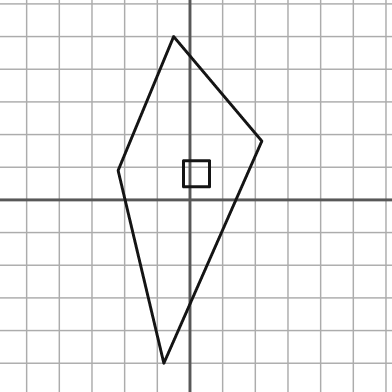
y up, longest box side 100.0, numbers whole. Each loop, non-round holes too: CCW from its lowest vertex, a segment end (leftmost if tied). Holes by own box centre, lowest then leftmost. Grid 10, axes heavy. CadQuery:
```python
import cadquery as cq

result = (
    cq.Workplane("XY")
    .moveTo(-8.0, -50.0)
    .lineTo(22.0, 18.0)
    .lineTo(-5.0, 50.0)
    .lineTo(-22.0, 9.0)
    .close()
    .moveTo(-2.0, 4.0)
    .lineTo(6.0, 4.0)
    .lineTo(6.0, 12.0)
    .lineTo(-2.0, 12.0)
    .close()
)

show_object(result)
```